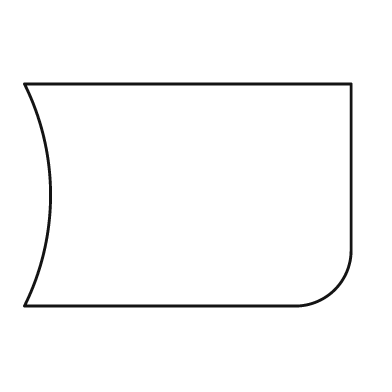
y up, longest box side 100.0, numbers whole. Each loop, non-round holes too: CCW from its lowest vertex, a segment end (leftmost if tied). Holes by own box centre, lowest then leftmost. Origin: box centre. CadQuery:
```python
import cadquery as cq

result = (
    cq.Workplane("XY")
    .moveTo(-50.0, -34.0)
    .lineTo(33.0, -34.0)
    .threePointArc((45.0, -29.0), (50.0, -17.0))
    .lineTo(50.0, 34.0)
    .lineTo(-50.0, 34.0)
    .threePointArc((-42.0, 0.0), (-50.0, -34.0))
    .close()
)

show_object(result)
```